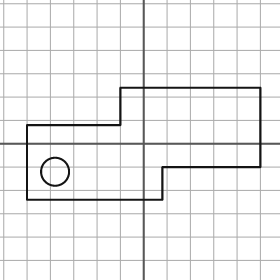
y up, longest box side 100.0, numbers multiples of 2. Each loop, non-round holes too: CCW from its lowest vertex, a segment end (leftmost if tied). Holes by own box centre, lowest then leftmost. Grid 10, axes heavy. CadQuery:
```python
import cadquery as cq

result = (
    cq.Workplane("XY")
    .moveTo(-50.0, -24.0)
    .lineTo(8.0, -24.0)
    .lineTo(8.0, -10.0)
    .lineTo(50.0, -10.0)
    .lineTo(50.0, 24.0)
    .lineTo(-10.0, 24.0)
    .lineTo(-10.0, 8.0)
    .lineTo(-50.0, 8.0)
    .close()
    .moveTo(-38.0, -12.0)
    .circle(6.0)
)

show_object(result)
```